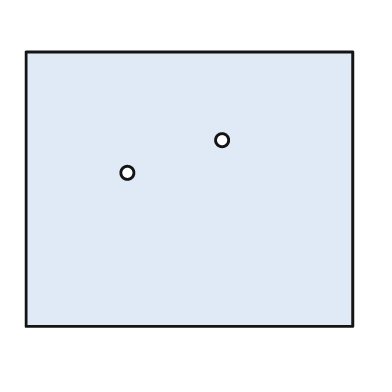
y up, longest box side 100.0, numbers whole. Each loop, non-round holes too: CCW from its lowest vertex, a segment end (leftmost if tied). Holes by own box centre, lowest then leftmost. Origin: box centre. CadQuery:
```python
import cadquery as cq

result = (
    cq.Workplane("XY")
    .moveTo(-50.0, -42.0)
    .lineTo(50.0, -42.0)
    .lineTo(50.0, 42.0)
    .lineTo(-50.0, 42.0)
    .close()
    .moveTo(-19.0, 5.0)
    .circle(2.0)
    .moveTo(10.0, 15.0)
    .circle(2.0)
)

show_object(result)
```